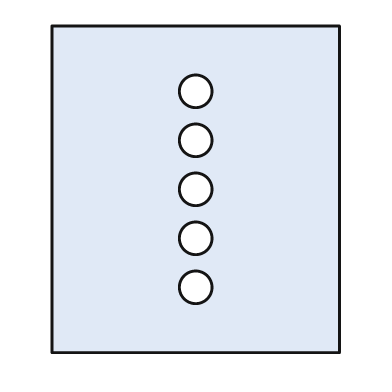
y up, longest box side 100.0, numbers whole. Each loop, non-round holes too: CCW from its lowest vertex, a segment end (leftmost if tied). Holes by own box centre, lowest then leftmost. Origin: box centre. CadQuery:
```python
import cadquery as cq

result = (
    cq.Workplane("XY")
    .moveTo(-44.0, -50.0)
    .lineTo(44.0, -50.0)
    .lineTo(44.0, 50.0)
    .lineTo(-44.0, 50.0)
    .close()
    .moveTo(0.0, -30.0)
    .circle(5.0)
    .moveTo(0.0, -15.0)
    .circle(5.0)
    .moveTo(0.0, 0.0)
    .circle(5.0)
    .moveTo(0.0, 15.0)
    .circle(5.0)
    .moveTo(0.0, 30.0)
    .circle(5.0)
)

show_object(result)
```